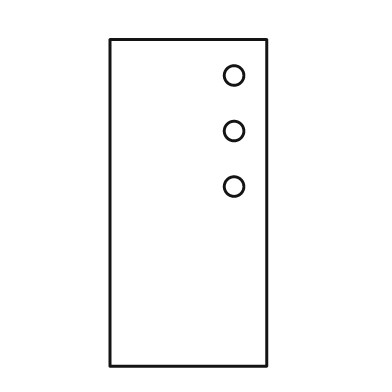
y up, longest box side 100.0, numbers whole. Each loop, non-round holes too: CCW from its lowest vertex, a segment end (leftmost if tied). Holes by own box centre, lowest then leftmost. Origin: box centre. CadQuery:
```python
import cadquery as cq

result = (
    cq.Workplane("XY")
    .moveTo(-24.0, -50.0)
    .lineTo(24.0, -50.0)
    .lineTo(24.0, 50.0)
    .lineTo(-24.0, 50.0)
    .close()
    .moveTo(14.0, 5.0)
    .circle(3.0)
    .moveTo(14.0, 22.0)
    .circle(3.0)
    .moveTo(14.0, 39.0)
    .circle(3.0)
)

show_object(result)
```